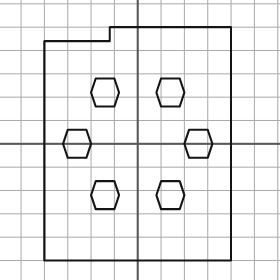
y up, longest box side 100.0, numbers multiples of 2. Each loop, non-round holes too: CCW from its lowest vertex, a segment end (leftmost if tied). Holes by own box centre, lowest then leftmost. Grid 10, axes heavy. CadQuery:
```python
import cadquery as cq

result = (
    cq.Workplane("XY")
    .moveTo(-40.0, -50.0)
    .lineTo(40.0, -50.0)
    .lineTo(40.0, 50.0)
    .lineTo(-12.0, 50.0)
    .lineTo(-12.0, 44.0)
    .lineTo(-40.0, 44.0)
    .close()
    .moveTo(-18.0, -28.0)
    .lineTo(-10.0, -28.0)
    .lineTo(-8.0, -22.0)
    .lineTo(-10.0, -16.0)
    .lineTo(-18.0, -16.0)
    .lineTo(-20.0, -22.0)
    .close()
    .moveTo(10.0, -28.0)
    .lineTo(18.0, -28.0)
    .lineTo(20.0, -22.0)
    .lineTo(18.0, -16.0)
    .lineTo(10.0, -16.0)
    .lineTo(8.0, -22.0)
    .close()
    .moveTo(-30.0, -6.0)
    .lineTo(-22.0, -6.0)
    .lineTo(-20.0, 0.0)
    .lineTo(-22.0, 6.0)
    .lineTo(-30.0, 6.0)
    .lineTo(-32.0, 0.0)
    .close()
    .moveTo(22.0, -6.0)
    .lineTo(30.0, -6.0)
    .lineTo(32.0, 0.0)
    .lineTo(30.0, 6.0)
    .lineTo(22.0, 6.0)
    .lineTo(20.0, 0.0)
    .close()
    .moveTo(-18.0, 16.0)
    .lineTo(-10.0, 16.0)
    .lineTo(-8.0, 22.0)
    .lineTo(-10.0, 28.0)
    .lineTo(-18.0, 28.0)
    .lineTo(-20.0, 22.0)
    .close()
    .moveTo(10.0, 16.0)
    .lineTo(18.0, 16.0)
    .lineTo(20.0, 22.0)
    .lineTo(18.0, 28.0)
    .lineTo(10.0, 28.0)
    .lineTo(8.0, 22.0)
    .close()
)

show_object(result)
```